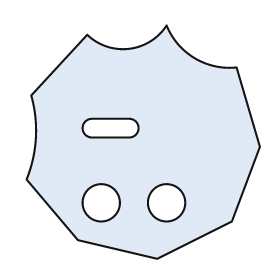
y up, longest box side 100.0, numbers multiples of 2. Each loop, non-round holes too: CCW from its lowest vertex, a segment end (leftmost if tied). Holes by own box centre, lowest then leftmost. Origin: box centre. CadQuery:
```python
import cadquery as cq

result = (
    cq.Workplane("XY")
    .moveTo(6.0, -50.0)
    .lineTo(38.0, -34.0)
    .lineTo(50.0, -2.0)
    .lineTo(40.0, 32.0)
    .threePointArc((22.0, 36.0), (10.0, 50.0))
    .threePointArc((-6.0, 40.0), (-24.0, 46.0))
    .lineTo(-48.0, 20.0)
    .threePointArc((-46.0, 2.0), (-50.0, -16.0))
    .lineTo(-28.0, -42.0)
    .close()
    .moveTo(-18.0, -26.0)
    .circle(8.0)
    .moveTo(10.0, -26.0)
    .circle(8.0)
    .moveTo(-22.0, 2.0)
    .lineTo(-6.0, 2.0)
    .threePointArc((-2.0, 6.0), (-6.0, 10.0))
    .lineTo(-22.0, 10.0)
    .threePointArc((-26.0, 6.0), (-22.0, 2.0))
    .close()
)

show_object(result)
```